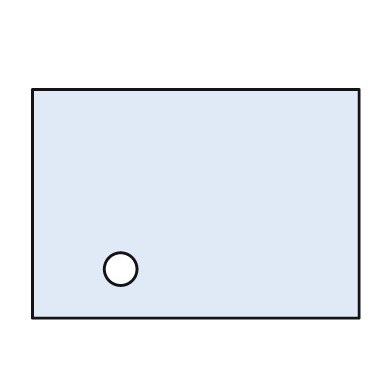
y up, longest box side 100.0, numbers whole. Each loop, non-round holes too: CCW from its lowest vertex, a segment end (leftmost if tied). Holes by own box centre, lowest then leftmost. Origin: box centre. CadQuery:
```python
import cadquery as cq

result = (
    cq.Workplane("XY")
    .moveTo(-50.0, -35.0)
    .lineTo(50.0, -35.0)
    .lineTo(50.0, 35.0)
    .lineTo(-50.0, 35.0)
    .close()
    .moveTo(-23.0, -20.0)
    .circle(5.0)
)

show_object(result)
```